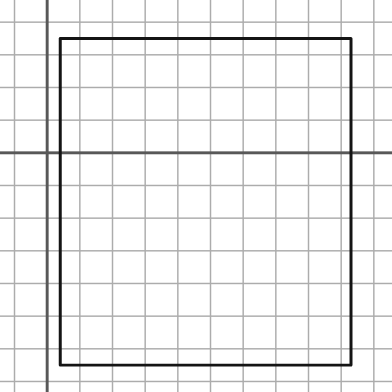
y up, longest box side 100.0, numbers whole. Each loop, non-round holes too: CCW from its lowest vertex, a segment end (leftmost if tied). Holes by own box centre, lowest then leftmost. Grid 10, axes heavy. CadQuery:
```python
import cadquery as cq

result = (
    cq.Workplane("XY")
    .moveTo(4.0, -65.0)
    .lineTo(93.0, -65.0)
    .lineTo(93.0, 35.0)
    .lineTo(4.0, 35.0)
    .close()
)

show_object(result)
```